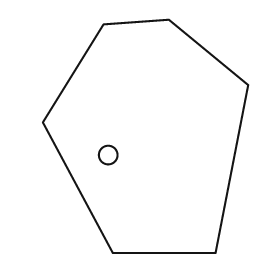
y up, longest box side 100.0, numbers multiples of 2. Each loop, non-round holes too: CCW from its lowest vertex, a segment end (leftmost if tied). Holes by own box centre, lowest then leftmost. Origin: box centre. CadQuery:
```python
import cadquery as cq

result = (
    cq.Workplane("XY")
    .moveTo(-14.0, -50.0)
    .lineTo(30.0, -50.0)
    .lineTo(44.0, 22.0)
    .lineTo(10.0, 50.0)
    .lineTo(-18.0, 48.0)
    .lineTo(-44.0, 6.0)
    .close()
    .moveTo(-16.0, -8.0)
    .circle(4.0)
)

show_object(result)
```